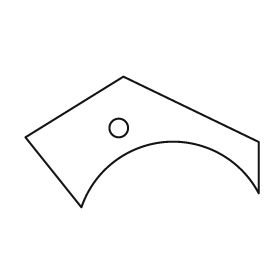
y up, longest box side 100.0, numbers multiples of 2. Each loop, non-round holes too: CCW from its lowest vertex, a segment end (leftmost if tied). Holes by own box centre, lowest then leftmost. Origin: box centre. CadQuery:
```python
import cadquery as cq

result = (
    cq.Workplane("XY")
    .moveTo(-26.0, -28.0)
    .threePointArc((10.0, 0.0), (50.0, -22.0))
    .lineTo(50.0, 0.0)
    .lineTo(-8.0, 28.0)
    .lineTo(-50.0, 2.0)
    .close()
    .moveTo(-10.0, 6.0)
    .circle(4.0)
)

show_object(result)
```